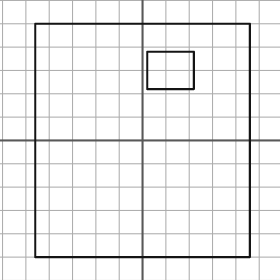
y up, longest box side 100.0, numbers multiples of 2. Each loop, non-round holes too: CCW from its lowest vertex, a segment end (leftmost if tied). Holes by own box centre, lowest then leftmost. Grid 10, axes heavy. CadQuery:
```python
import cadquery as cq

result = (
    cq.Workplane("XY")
    .moveTo(-46.0, -50.0)
    .lineTo(46.0, -50.0)
    .lineTo(46.0, 50.0)
    .lineTo(-46.0, 50.0)
    .close()
    .moveTo(2.0, 22.0)
    .lineTo(22.0, 22.0)
    .lineTo(22.0, 38.0)
    .lineTo(2.0, 38.0)
    .close()
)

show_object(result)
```